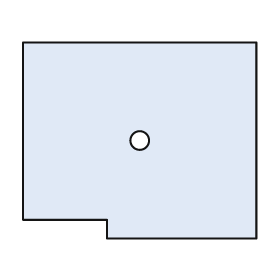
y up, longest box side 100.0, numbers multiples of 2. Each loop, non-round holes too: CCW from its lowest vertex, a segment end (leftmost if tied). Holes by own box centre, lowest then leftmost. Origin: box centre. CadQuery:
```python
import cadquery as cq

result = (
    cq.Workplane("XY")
    .moveTo(-14.0, -42.0)
    .lineTo(50.0, -42.0)
    .lineTo(50.0, 42.0)
    .lineTo(-50.0, 42.0)
    .lineTo(-50.0, -34.0)
    .lineTo(-14.0, -34.0)
    .close()
    .moveTo(0.0, 0.0)
    .circle(4.0)
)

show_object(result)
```